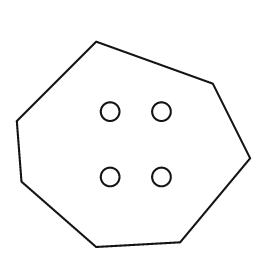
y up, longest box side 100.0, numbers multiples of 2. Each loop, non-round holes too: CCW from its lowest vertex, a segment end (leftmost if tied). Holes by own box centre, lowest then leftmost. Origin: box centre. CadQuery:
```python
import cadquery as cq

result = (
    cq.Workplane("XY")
    .moveTo(-16.0, -44.0)
    .lineTo(20.0, -42.0)
    .lineTo(50.0, -6.0)
    .lineTo(34.0, 26.0)
    .lineTo(-16.0, 44.0)
    .lineTo(-50.0, 10.0)
    .lineTo(-48.0, -16.0)
    .close()
    .moveTo(-10.0, -14.0)
    .circle(4.0)
    .moveTo(12.0, -14.0)
    .circle(4.0)
    .moveTo(-10.0, 14.0)
    .circle(4.0)
    .moveTo(12.0, 14.0)
    .circle(4.0)
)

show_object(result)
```